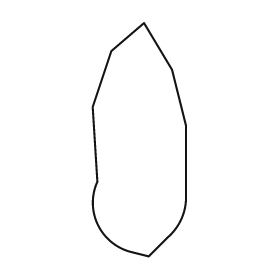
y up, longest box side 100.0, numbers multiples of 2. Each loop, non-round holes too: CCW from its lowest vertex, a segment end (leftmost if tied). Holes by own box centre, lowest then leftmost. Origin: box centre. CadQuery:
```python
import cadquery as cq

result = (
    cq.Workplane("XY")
    .moveTo(4.0, -50.0)
    .lineTo(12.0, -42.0)
    .threePointArc((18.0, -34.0), (20.0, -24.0))
    .lineTo(20.0, 6.0)
    .lineTo(14.0, 30.0)
    .lineTo(2.0, 50.0)
    .lineTo(-12.0, 38.0)
    .lineTo(-20.0, 14.0)
    .lineTo(-18.0, -18.0)
    .threePointArc((-18.0, -36.0), (-4.0, -48.0))
    .close()
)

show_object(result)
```